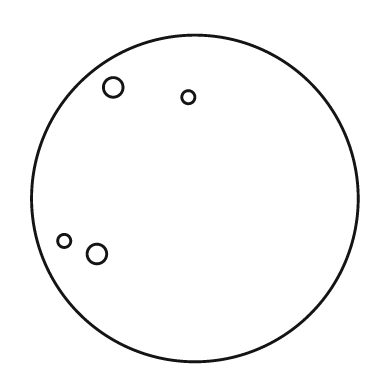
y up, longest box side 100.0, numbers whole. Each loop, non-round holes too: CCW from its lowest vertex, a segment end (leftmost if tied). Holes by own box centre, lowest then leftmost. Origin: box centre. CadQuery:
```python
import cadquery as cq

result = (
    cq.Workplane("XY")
    .moveTo(0.0, 0.0)
    .circle(50.0)
    .moveTo(-30.0, -17.0)
    .circle(3.0)
    .moveTo(-40.0, -13.0)
    .circle(2.0)
    .moveTo(-2.0, 31.0)
    .circle(2.0)
    .moveTo(-25.0, 34.0)
    .circle(3.0)
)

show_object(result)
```